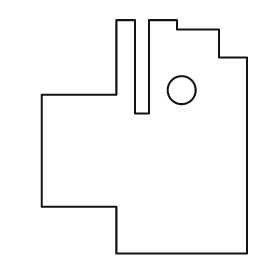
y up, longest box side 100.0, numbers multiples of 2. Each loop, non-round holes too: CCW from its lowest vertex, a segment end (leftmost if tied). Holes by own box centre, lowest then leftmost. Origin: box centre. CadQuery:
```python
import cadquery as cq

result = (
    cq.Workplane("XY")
    .moveTo(-12.0, -50.0)
    .lineTo(44.0, -50.0)
    .lineTo(44.0, 34.0)
    .lineTo(32.0, 34.0)
    .lineTo(32.0, 46.0)
    .lineTo(14.0, 46.0)
    .lineTo(14.0, 50.0)
    .lineTo(2.0, 50.0)
    .lineTo(2.0, 10.0)
    .lineTo(-4.0, 10.0)
    .lineTo(-4.0, 50.0)
    .lineTo(-12.0, 50.0)
    .lineTo(-12.0, 18.0)
    .lineTo(-44.0, 18.0)
    .lineTo(-44.0, -30.0)
    .lineTo(-12.0, -30.0)
    .close()
    .moveTo(16.0, 20.0)
    .circle(6.0)
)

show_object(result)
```